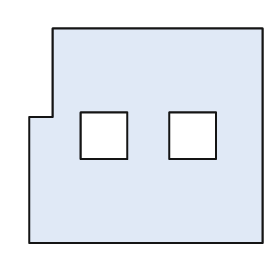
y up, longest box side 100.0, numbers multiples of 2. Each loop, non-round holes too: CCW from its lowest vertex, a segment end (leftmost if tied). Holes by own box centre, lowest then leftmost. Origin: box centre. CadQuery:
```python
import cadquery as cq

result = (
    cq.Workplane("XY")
    .moveTo(-50.0, -46.0)
    .lineTo(50.0, -46.0)
    .lineTo(50.0, 46.0)
    .lineTo(-40.0, 46.0)
    .lineTo(-40.0, 8.0)
    .lineTo(-50.0, 8.0)
    .close()
    .moveTo(-28.0, -10.0)
    .lineTo(-8.0, -10.0)
    .lineTo(-8.0, 10.0)
    .lineTo(-28.0, 10.0)
    .close()
    .moveTo(10.0, -10.0)
    .lineTo(30.0, -10.0)
    .lineTo(30.0, 10.0)
    .lineTo(10.0, 10.0)
    .close()
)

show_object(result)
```